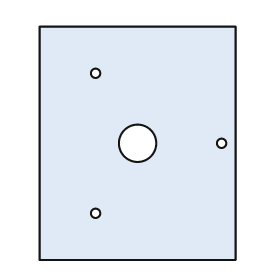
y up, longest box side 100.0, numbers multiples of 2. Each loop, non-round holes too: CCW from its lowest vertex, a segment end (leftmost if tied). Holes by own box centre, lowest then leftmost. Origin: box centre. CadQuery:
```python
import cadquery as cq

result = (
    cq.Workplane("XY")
    .moveTo(-42.0, -50.0)
    .lineTo(42.0, -50.0)
    .lineTo(42.0, 50.0)
    .lineTo(-42.0, 50.0)
    .close()
    .moveTo(-18.0, -30.0)
    .circle(2.0)
    .moveTo(0.0, 0.0)
    .circle(8.0)
    .moveTo(36.0, 0.0)
    .circle(2.0)
    .moveTo(-18.0, 30.0)
    .circle(2.0)
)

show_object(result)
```